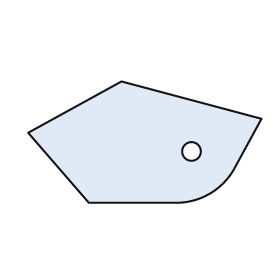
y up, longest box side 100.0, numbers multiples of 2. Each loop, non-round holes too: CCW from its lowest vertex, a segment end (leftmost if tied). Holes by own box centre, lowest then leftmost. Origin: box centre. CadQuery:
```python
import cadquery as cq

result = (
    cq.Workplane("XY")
    .moveTo(-24.0, -26.0)
    .lineTo(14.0, -26.0)
    .threePointArc((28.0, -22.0), (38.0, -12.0))
    .lineTo(50.0, 10.0)
    .lineTo(-10.0, 26.0)
    .lineTo(-50.0, 4.0)
    .close()
    .moveTo(20.0, -4.0)
    .circle(4.0)
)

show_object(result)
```